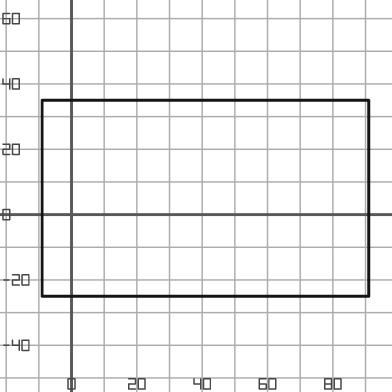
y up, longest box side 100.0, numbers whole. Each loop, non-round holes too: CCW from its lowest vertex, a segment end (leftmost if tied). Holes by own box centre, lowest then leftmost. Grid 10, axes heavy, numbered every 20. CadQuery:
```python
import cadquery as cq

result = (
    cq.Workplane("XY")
    .moveTo(-9.0, -25.0)
    .lineTo(91.0, -25.0)
    .lineTo(91.0, 35.0)
    .lineTo(-9.0, 35.0)
    .close()
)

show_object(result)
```